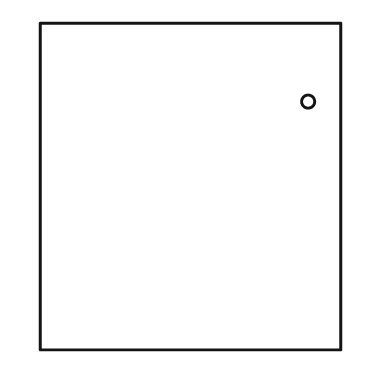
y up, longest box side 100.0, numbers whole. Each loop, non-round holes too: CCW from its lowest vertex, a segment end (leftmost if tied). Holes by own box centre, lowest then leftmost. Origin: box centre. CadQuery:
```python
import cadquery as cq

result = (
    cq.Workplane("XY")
    .moveTo(-46.0, -50.0)
    .lineTo(46.0, -50.0)
    .lineTo(46.0, 50.0)
    .lineTo(-46.0, 50.0)
    .close()
    .moveTo(36.0, 26.0)
    .circle(2.0)
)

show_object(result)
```